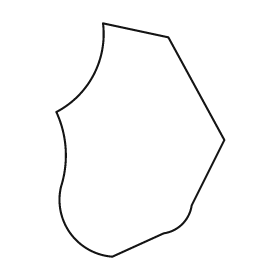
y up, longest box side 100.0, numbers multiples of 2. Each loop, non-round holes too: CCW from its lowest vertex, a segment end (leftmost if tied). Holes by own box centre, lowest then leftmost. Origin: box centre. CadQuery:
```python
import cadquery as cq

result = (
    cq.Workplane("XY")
    .moveTo(-12.0, -50.0)
    .lineTo(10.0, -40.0)
    .threePointArc((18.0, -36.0), (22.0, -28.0))
    .lineTo(36.0, 0.0)
    .lineTo(12.0, 44.0)
    .lineTo(-16.0, 50.0)
    .threePointArc((-20.0, 28.0), (-36.0, 12.0))
    .threePointArc((-32.0, -4.0), (-34.0, -20.0))
    .threePointArc((-30.0, -40.0), (-12.0, -50.0))
    .close()
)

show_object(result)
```